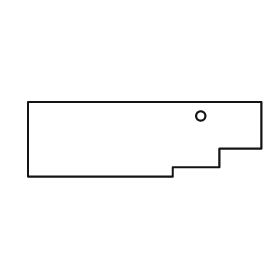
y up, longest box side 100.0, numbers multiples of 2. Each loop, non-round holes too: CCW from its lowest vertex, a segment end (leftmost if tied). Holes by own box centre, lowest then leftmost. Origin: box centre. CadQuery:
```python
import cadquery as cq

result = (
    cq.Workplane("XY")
    .moveTo(-50.0, -16.0)
    .lineTo(12.0, -16.0)
    .lineTo(12.0, -12.0)
    .lineTo(32.0, -12.0)
    .lineTo(32.0, -4.0)
    .lineTo(50.0, -4.0)
    .lineTo(50.0, 16.0)
    .lineTo(-50.0, 16.0)
    .close()
    .moveTo(24.0, 10.0)
    .circle(2.0)
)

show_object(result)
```